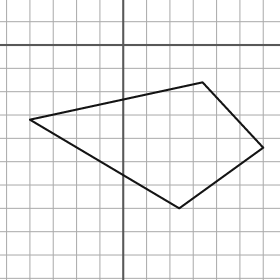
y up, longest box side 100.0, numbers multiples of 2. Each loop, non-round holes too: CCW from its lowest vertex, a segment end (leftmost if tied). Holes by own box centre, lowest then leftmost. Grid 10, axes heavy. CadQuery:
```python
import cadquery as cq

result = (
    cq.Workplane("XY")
    .moveTo(24.0, -70.0)
    .lineTo(60.0, -44.0)
    .lineTo(34.0, -16.0)
    .lineTo(-40.0, -32.0)
    .close()
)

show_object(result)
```